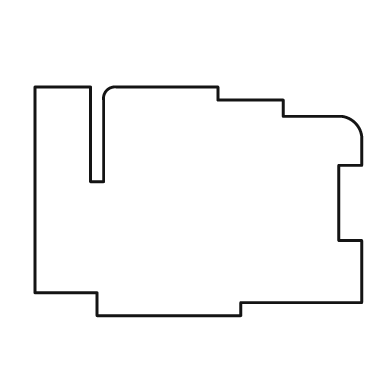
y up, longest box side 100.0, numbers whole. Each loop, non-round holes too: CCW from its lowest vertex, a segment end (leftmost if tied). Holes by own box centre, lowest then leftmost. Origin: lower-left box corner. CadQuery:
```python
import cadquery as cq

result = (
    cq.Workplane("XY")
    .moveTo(19.0, 0.0)
    .lineTo(63.0, 0.0)
    .lineTo(63.0, 4.0)
    .lineTo(100.0, 4.0)
    .lineTo(100.0, 23.0)
    .lineTo(93.0, 23.0)
    .lineTo(93.0, 46.0)
    .lineTo(100.0, 46.0)
    .lineTo(100.0, 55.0)
    .threePointArc((98.0, 59.0), (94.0, 61.0))
    .lineTo(76.0, 61.0)
    .lineTo(76.0, 66.0)
    .lineTo(56.0, 66.0)
    .lineTo(56.0, 70.0)
    .lineTo(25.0, 70.0)
    .threePointArc((22.0, 69.0), (21.0, 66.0))
    .lineTo(21.0, 41.0)
    .lineTo(17.0, 41.0)
    .lineTo(17.0, 70.0)
    .lineTo(0.0, 70.0)
    .lineTo(0.0, 7.0)
    .lineTo(19.0, 7.0)
    .close()
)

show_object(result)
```